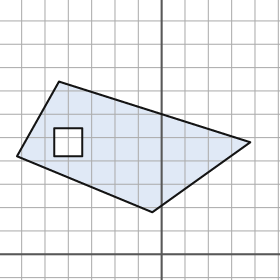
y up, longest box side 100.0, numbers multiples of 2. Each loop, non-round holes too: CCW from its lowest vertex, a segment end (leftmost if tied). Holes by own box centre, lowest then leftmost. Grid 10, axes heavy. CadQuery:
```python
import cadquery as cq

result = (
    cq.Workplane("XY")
    .moveTo(-4.0, 18.0)
    .lineTo(38.0, 48.0)
    .lineTo(-44.0, 74.0)
    .lineTo(-62.0, 42.0)
    .close()
    .moveTo(-46.0, 42.0)
    .lineTo(-34.0, 42.0)
    .lineTo(-34.0, 54.0)
    .lineTo(-46.0, 54.0)
    .close()
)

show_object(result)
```